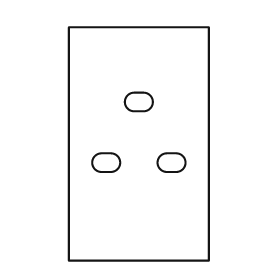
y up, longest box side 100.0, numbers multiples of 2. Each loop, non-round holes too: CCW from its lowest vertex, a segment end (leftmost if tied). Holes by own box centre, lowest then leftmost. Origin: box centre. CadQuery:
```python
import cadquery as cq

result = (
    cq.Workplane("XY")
    .moveTo(-30.0, -50.0)
    .lineTo(30.0, -50.0)
    .lineTo(30.0, 50.0)
    .lineTo(-30.0, 50.0)
    .close()
    .moveTo(-16.0, -12.0)
    .lineTo(-12.0, -12.0)
    .threePointArc((-8.0, -8.0), (-12.0, -4.0))
    .lineTo(-16.0, -4.0)
    .threePointArc((-20.0, -8.0), (-16.0, -12.0))
    .close()
    .moveTo(12.0, -12.0)
    .lineTo(16.0, -12.0)
    .threePointArc((20.0, -8.0), (16.0, -4.0))
    .lineTo(12.0, -4.0)
    .threePointArc((8.0, -8.0), (12.0, -12.0))
    .close()
    .moveTo(-2.0, 14.0)
    .lineTo(2.0, 14.0)
    .threePointArc((6.0, 18.0), (2.0, 22.0))
    .lineTo(-2.0, 22.0)
    .threePointArc((-6.0, 18.0), (-2.0, 14.0))
    .close()
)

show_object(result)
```